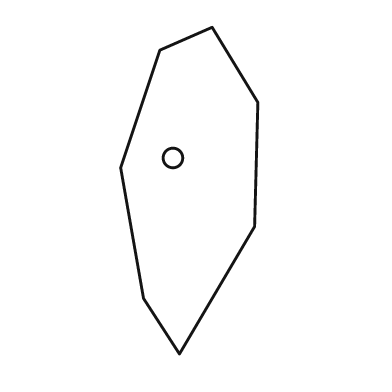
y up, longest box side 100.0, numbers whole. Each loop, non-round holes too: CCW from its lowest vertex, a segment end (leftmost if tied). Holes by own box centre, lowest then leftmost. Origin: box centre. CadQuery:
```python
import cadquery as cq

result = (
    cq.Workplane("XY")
    .moveTo(-3.0, -50.0)
    .lineTo(20.0, -11.0)
    .lineTo(21.0, 27.0)
    .lineTo(7.0, 50.0)
    .lineTo(-9.0, 43.0)
    .lineTo(-21.0, 7.0)
    .lineTo(-14.0, -33.0)
    .close()
    .moveTo(-5.0, 10.0)
    .circle(3.0)
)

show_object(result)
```